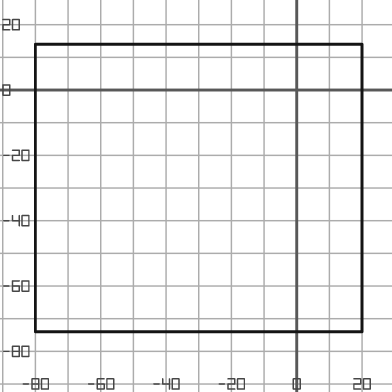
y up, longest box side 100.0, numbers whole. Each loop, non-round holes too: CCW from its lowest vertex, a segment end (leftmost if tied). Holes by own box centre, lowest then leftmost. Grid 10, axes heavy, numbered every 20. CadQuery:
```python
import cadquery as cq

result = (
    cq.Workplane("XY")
    .moveTo(-80.0, -74.0)
    .lineTo(20.0, -74.0)
    .lineTo(20.0, 14.0)
    .lineTo(-80.0, 14.0)
    .close()
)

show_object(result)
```